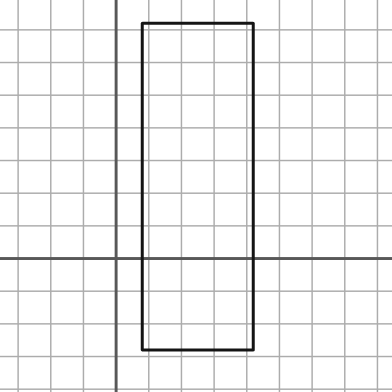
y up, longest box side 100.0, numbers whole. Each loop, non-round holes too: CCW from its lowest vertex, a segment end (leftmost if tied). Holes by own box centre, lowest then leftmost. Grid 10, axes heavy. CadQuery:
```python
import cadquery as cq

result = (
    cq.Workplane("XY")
    .moveTo(8.0, -28.0)
    .lineTo(42.0, -28.0)
    .lineTo(42.0, 72.0)
    .lineTo(8.0, 72.0)
    .close()
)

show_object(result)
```